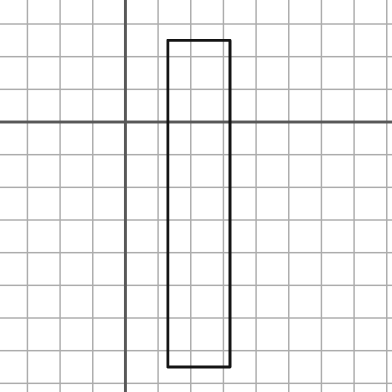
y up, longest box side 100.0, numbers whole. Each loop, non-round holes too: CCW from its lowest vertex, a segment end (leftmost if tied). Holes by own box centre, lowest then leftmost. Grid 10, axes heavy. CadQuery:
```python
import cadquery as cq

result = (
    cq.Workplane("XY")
    .moveTo(13.0, -75.0)
    .lineTo(32.0, -75.0)
    .lineTo(32.0, 25.0)
    .lineTo(13.0, 25.0)
    .close()
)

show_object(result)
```